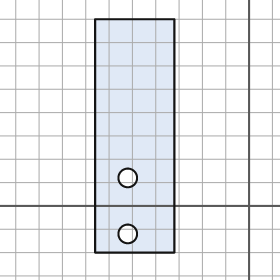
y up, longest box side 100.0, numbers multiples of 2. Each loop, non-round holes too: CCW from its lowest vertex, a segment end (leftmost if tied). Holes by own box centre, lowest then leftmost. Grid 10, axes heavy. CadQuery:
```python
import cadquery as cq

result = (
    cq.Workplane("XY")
    .moveTo(-66.0, -20.0)
    .lineTo(-32.0, -20.0)
    .lineTo(-32.0, 80.0)
    .lineTo(-66.0, 80.0)
    .close()
    .moveTo(-52.0, -12.0)
    .circle(4.0)
    .moveTo(-52.0, 12.0)
    .circle(4.0)
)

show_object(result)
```